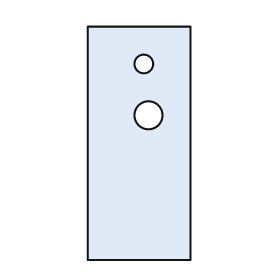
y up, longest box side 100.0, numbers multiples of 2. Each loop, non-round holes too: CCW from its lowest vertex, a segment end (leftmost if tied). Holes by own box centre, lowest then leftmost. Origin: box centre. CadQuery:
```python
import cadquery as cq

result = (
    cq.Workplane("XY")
    .moveTo(-22.0, -50.0)
    .lineTo(22.0, -50.0)
    .lineTo(22.0, 50.0)
    .lineTo(-22.0, 50.0)
    .close()
    .moveTo(4.0, 12.0)
    .circle(6.0)
    .moveTo(2.0, 34.0)
    .circle(4.0)
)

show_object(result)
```